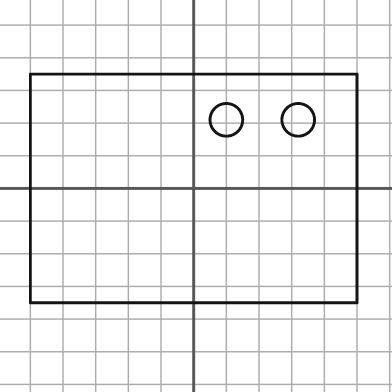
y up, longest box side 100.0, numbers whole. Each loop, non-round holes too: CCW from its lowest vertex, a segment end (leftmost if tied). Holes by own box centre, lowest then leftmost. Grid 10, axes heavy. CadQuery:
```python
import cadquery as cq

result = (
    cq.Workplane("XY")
    .moveTo(-50.0, -35.0)
    .lineTo(50.0, -35.0)
    .lineTo(50.0, 35.0)
    .lineTo(-50.0, 35.0)
    .close()
    .moveTo(10.0, 21.0)
    .circle(5.0)
    .moveTo(32.0, 21.0)
    .circle(5.0)
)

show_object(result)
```